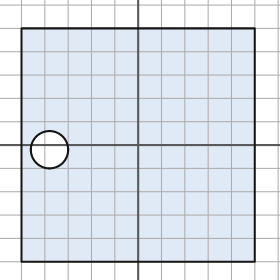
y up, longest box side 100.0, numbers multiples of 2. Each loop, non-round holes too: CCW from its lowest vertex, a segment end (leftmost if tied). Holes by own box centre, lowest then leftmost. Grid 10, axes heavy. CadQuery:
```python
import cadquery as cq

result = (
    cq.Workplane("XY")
    .moveTo(-50.0, -50.0)
    .lineTo(50.0, -50.0)
    .lineTo(50.0, 50.0)
    .lineTo(-50.0, 50.0)
    .close()
    .moveTo(-38.0, -2.0)
    .circle(8.0)
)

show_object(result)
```